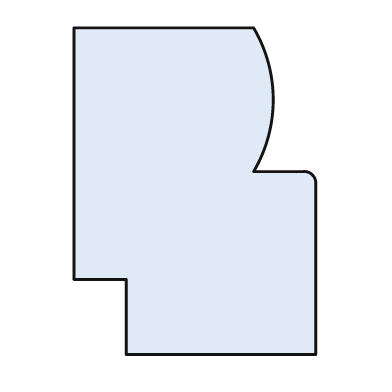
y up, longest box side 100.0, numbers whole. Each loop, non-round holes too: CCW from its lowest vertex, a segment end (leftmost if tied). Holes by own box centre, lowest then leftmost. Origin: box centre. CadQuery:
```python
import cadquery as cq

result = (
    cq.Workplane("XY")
    .moveTo(-21.0, -50.0)
    .lineTo(37.0, -50.0)
    .lineTo(37.0, 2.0)
    .threePointArc((36.0, 5.0), (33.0, 6.0))
    .lineTo(18.0, 6.0)
    .threePointArc((24.0, 28.0), (18.0, 50.0))
    .lineTo(-37.0, 50.0)
    .lineTo(-37.0, -27.0)
    .lineTo(-21.0, -27.0)
    .close()
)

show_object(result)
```